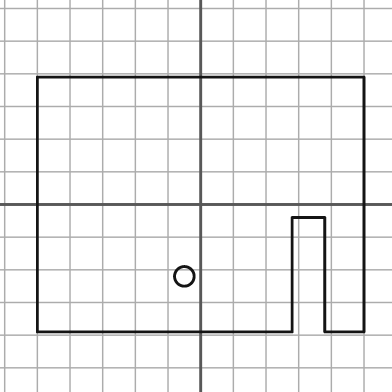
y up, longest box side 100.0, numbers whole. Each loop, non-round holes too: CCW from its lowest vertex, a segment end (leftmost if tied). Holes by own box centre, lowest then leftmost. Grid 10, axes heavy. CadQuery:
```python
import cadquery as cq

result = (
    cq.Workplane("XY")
    .moveTo(-50.0, -39.0)
    .lineTo(28.0, -39.0)
    .lineTo(28.0, -4.0)
    .lineTo(38.0, -4.0)
    .lineTo(38.0, -39.0)
    .lineTo(50.0, -39.0)
    .lineTo(50.0, 39.0)
    .lineTo(-50.0, 39.0)
    .close()
    .moveTo(-5.0, -22.0)
    .circle(3.0)
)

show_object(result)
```